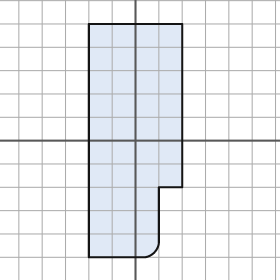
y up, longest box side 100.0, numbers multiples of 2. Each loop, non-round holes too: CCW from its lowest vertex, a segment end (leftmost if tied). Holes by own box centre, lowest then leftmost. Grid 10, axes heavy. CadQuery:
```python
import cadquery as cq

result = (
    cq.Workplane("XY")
    .moveTo(-20.0, -50.0)
    .lineTo(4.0, -50.0)
    .threePointArc((8.0, -48.0), (10.0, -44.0))
    .lineTo(10.0, -20.0)
    .lineTo(20.0, -20.0)
    .lineTo(20.0, 50.0)
    .lineTo(-20.0, 50.0)
    .close()
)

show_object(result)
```